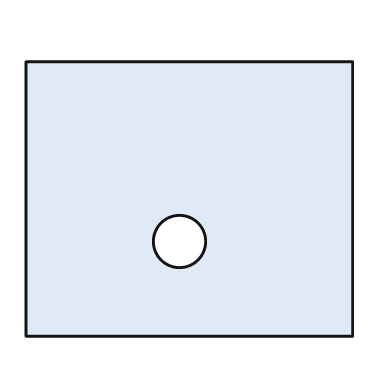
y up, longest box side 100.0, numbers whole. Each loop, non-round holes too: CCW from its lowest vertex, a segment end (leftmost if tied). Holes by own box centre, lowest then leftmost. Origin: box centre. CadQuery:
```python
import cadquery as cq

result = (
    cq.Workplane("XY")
    .moveTo(-50.0, -42.0)
    .lineTo(50.0, -42.0)
    .lineTo(50.0, 42.0)
    .lineTo(-50.0, 42.0)
    .close()
    .moveTo(-3.0, -13.0)
    .circle(8.0)
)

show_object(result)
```